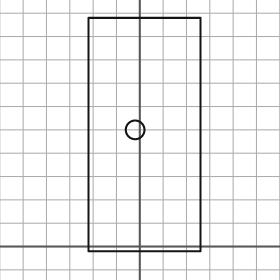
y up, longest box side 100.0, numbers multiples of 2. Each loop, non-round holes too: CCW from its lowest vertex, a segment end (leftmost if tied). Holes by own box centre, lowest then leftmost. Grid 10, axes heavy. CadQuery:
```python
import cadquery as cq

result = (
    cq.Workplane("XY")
    .moveTo(-22.0, -2.0)
    .lineTo(26.0, -2.0)
    .lineTo(26.0, 98.0)
    .lineTo(-22.0, 98.0)
    .close()
    .moveTo(-2.0, 50.0)
    .circle(4.0)
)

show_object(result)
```